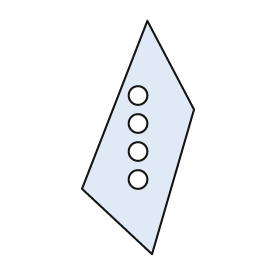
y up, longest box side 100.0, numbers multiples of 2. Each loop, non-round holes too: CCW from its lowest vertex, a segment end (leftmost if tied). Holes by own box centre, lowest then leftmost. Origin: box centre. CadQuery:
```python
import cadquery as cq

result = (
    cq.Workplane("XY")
    .moveTo(6.0, -50.0)
    .lineTo(24.0, 12.0)
    .lineTo(4.0, 50.0)
    .lineTo(-24.0, -22.0)
    .close()
    .moveTo(0.0, -18.0)
    .circle(4.0)
    .moveTo(0.0, -6.0)
    .circle(4.0)
    .moveTo(0.0, 6.0)
    .circle(4.0)
    .moveTo(0.0, 18.0)
    .circle(4.0)
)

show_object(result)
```